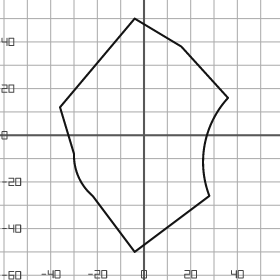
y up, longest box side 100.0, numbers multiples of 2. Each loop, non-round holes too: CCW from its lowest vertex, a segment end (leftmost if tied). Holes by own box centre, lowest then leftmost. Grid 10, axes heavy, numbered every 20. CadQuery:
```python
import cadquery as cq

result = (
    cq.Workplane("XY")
    .moveTo(-4.0, -50.0)
    .lineTo(28.0, -26.0)
    .threePointArc((26.0, -4.0), (36.0, 16.0))
    .lineTo(16.0, 38.0)
    .lineTo(-4.0, 50.0)
    .lineTo(-36.0, 12.0)
    .lineTo(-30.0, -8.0)
    .threePointArc((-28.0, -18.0), (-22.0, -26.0))
    .close()
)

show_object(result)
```